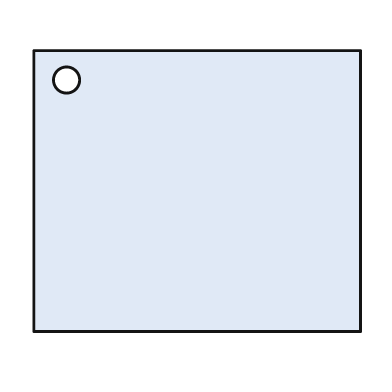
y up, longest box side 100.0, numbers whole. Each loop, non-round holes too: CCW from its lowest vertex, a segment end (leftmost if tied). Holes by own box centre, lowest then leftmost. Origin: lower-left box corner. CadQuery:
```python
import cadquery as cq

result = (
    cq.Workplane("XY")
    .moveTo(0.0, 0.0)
    .lineTo(100.0, 0.0)
    .lineTo(100.0, 86.0)
    .lineTo(0.0, 86.0)
    .close()
    .moveTo(10.0, 77.0)
    .circle(4.0)
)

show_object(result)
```